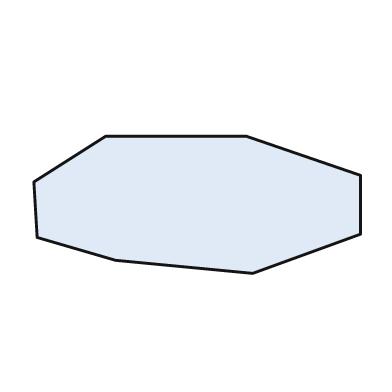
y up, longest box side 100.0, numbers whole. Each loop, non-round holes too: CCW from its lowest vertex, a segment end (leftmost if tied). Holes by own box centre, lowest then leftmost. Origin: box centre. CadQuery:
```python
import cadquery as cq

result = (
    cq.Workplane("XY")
    .moveTo(17.0, -21.0)
    .lineTo(50.0, -9.0)
    .lineTo(50.0, 9.0)
    .lineTo(15.0, 21.0)
    .lineTo(-28.0, 21.0)
    .lineTo(-50.0, 7.0)
    .lineTo(-49.0, -10.0)
    .lineTo(-25.0, -17.0)
    .close()
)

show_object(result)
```